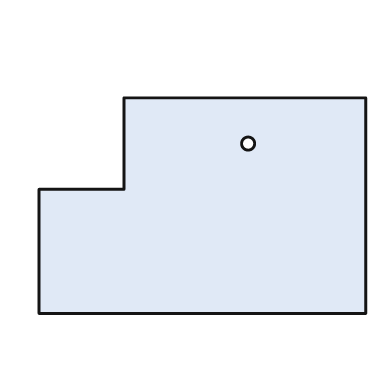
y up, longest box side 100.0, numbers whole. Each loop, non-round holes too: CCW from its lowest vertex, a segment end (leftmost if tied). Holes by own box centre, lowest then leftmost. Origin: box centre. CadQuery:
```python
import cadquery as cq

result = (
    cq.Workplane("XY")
    .moveTo(-50.0, -33.0)
    .lineTo(50.0, -33.0)
    .lineTo(50.0, 33.0)
    .lineTo(-24.0, 33.0)
    .lineTo(-24.0, 5.0)
    .lineTo(-50.0, 5.0)
    .close()
    .moveTo(14.0, 19.0)
    .circle(2.0)
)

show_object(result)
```